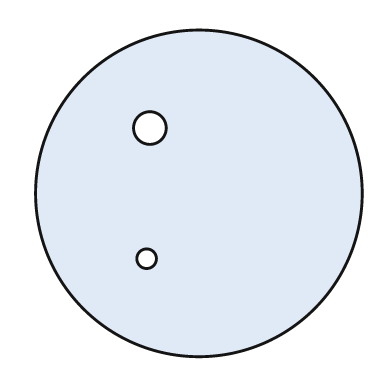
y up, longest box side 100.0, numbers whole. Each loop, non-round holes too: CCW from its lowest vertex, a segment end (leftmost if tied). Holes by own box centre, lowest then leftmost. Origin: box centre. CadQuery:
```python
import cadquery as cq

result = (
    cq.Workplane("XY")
    .moveTo(0.0, 0.0)
    .circle(50.0)
    .moveTo(-16.0, -20.0)
    .circle(3.0)
    .moveTo(-15.0, 20.0)
    .circle(5.0)
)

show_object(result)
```